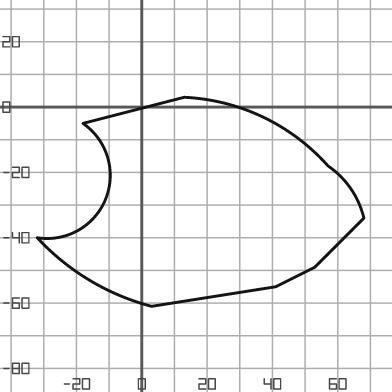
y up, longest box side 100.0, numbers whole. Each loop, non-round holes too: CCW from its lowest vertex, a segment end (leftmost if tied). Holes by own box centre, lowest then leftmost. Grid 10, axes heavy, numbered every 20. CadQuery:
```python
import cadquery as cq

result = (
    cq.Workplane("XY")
    .moveTo(3.0, -61.0)
    .lineTo(41.0, -55.0)
    .lineTo(53.0, -49.0)
    .lineTo(68.0, -34.0)
    .threePointArc((64.0, -25.0), (57.0, -18.0))
    .threePointArc((37.0, -3.0), (13.0, 3.0))
    .lineTo(-18.0, -5.0)
    .threePointArc((-11.0, -28.0), (-32.0, -40.0))
    .threePointArc((-16.0, -53.0), (3.0, -61.0))
    .close()
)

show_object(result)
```